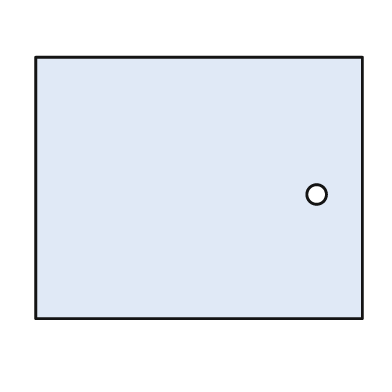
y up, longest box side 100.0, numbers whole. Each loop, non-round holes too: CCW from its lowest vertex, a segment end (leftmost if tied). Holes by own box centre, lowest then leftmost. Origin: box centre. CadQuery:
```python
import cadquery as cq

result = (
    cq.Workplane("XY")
    .moveTo(-50.0, -40.0)
    .lineTo(50.0, -40.0)
    .lineTo(50.0, 40.0)
    .lineTo(-50.0, 40.0)
    .close()
    .moveTo(36.0, -2.0)
    .circle(3.0)
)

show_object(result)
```